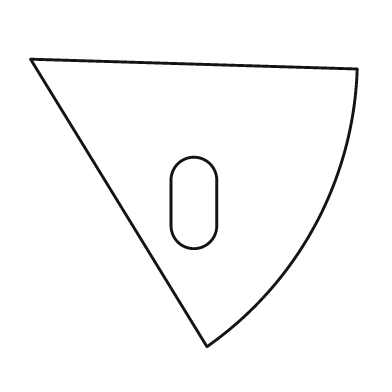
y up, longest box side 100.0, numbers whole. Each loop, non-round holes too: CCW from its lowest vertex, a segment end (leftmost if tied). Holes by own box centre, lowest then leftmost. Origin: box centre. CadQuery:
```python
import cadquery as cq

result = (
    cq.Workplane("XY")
    .moveTo(4.0, -44.0)
    .threePointArc((37.0, -7.0), (50.0, 41.0))
    .lineTo(-50.0, 44.0)
    .close()
    .moveTo(-7.0, -7.0)
    .threePointArc((0.0, -14.0), (7.0, -7.0))
    .lineTo(7.0, 7.0)
    .threePointArc((0.0, 14.0), (-7.0, 7.0))
    .close()
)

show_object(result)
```